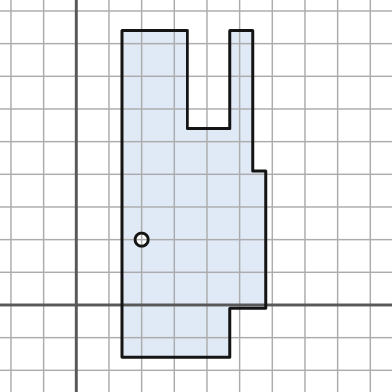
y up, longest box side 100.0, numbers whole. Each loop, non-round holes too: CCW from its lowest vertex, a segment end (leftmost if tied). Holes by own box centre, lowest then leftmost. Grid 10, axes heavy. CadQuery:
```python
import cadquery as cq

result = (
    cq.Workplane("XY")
    .moveTo(14.0, -16.0)
    .lineTo(47.0, -16.0)
    .lineTo(47.0, -1.0)
    .lineTo(58.0, -1.0)
    .lineTo(58.0, 41.0)
    .lineTo(54.0, 41.0)
    .lineTo(54.0, 84.0)
    .lineTo(47.0, 84.0)
    .lineTo(47.0, 54.0)
    .lineTo(34.0, 54.0)
    .lineTo(34.0, 84.0)
    .lineTo(14.0, 84.0)
    .close()
    .moveTo(20.0, 20.0)
    .circle(2.0)
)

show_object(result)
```